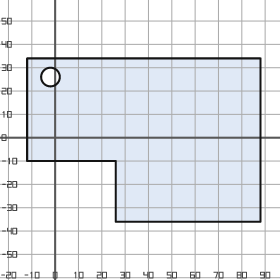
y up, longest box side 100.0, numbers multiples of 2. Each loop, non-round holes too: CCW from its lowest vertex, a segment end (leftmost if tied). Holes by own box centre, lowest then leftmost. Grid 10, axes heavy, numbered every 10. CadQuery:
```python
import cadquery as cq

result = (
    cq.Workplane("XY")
    .moveTo(26.0, -36.0)
    .lineTo(88.0, -36.0)
    .lineTo(88.0, 34.0)
    .lineTo(-12.0, 34.0)
    .lineTo(-12.0, -10.0)
    .lineTo(26.0, -10.0)
    .close()
    .moveTo(-2.0, 26.0)
    .circle(4.0)
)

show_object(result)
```